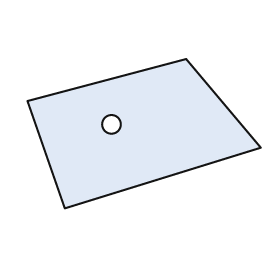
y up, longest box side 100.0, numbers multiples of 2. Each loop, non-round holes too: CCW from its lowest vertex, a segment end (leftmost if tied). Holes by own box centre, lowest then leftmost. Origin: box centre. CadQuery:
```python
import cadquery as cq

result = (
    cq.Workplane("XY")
    .moveTo(-34.0, -32.0)
    .lineTo(50.0, -6.0)
    .lineTo(18.0, 32.0)
    .lineTo(-50.0, 14.0)
    .close()
    .moveTo(-14.0, 4.0)
    .circle(4.0)
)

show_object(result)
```